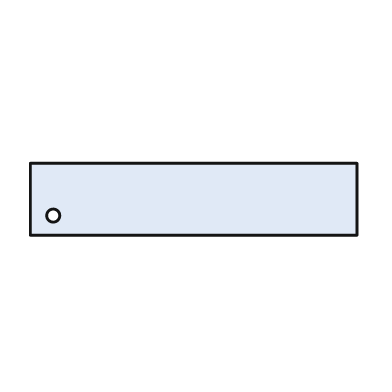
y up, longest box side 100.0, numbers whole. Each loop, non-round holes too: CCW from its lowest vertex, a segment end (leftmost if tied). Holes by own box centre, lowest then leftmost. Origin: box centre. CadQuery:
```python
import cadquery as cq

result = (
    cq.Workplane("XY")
    .moveTo(-50.0, -11.0)
    .lineTo(50.0, -11.0)
    .lineTo(50.0, 11.0)
    .lineTo(-50.0, 11.0)
    .close()
    .moveTo(-43.0, -5.0)
    .circle(2.0)
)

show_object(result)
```